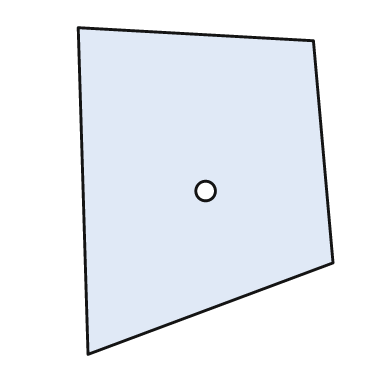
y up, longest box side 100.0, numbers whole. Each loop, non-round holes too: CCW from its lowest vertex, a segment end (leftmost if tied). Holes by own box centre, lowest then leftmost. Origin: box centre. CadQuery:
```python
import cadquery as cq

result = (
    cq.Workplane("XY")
    .moveTo(-36.0, -50.0)
    .lineTo(39.0, -22.0)
    .lineTo(33.0, 46.0)
    .lineTo(-39.0, 50.0)
    .close()
    .moveTo(0.0, 0.0)
    .circle(3.0)
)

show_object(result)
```